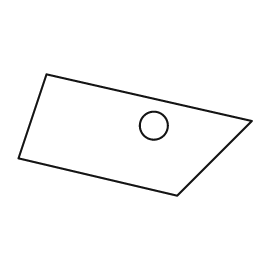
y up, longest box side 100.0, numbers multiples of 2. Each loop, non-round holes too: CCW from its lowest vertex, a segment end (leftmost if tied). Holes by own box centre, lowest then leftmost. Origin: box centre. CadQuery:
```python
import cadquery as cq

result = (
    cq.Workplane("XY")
    .moveTo(18.0, -26.0)
    .lineTo(50.0, 6.0)
    .lineTo(-38.0, 26.0)
    .lineTo(-50.0, -10.0)
    .close()
    .moveTo(8.0, 4.0)
    .circle(6.0)
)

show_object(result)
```